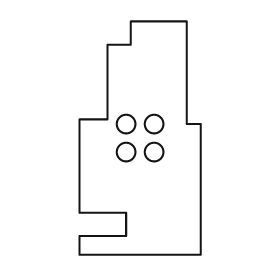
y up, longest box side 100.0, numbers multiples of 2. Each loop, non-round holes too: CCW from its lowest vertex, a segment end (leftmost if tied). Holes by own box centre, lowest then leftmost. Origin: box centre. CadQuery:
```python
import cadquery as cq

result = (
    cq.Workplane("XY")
    .moveTo(-26.0, -50.0)
    .lineTo(26.0, -50.0)
    .lineTo(26.0, 6.0)
    .lineTo(20.0, 6.0)
    .lineTo(20.0, 50.0)
    .lineTo(-4.0, 50.0)
    .lineTo(-4.0, 40.0)
    .lineTo(-14.0, 40.0)
    .lineTo(-14.0, 8.0)
    .lineTo(-26.0, 8.0)
    .lineTo(-26.0, -32.0)
    .lineTo(-6.0, -32.0)
    .lineTo(-6.0, -42.0)
    .lineTo(-26.0, -42.0)
    .close()
    .moveTo(-6.0, -6.0)
    .circle(4.0)
    .moveTo(6.0, -6.0)
    .circle(4.0)
    .moveTo(-6.0, 6.0)
    .circle(4.0)
    .moveTo(6.0, 6.0)
    .circle(4.0)
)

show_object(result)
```